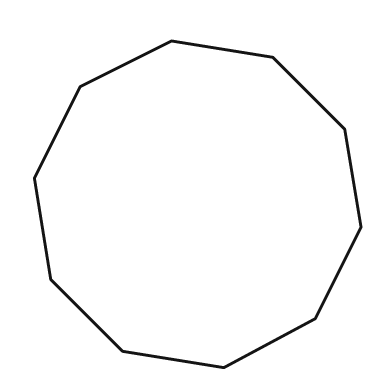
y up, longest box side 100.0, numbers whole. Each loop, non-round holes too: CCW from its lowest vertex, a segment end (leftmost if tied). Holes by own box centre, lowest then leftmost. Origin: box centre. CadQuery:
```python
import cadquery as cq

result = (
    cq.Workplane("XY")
    .moveTo(8.0, -50.0)
    .lineTo(36.0, -35.0)
    .lineTo(50.0, -7.0)
    .lineTo(45.0, 23.0)
    .lineTo(23.0, 45.0)
    .lineTo(-8.0, 50.0)
    .lineTo(-36.0, 36.0)
    .lineTo(-50.0, 8.0)
    .lineTo(-45.0, -23.0)
    .lineTo(-23.0, -45.0)
    .close()
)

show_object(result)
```